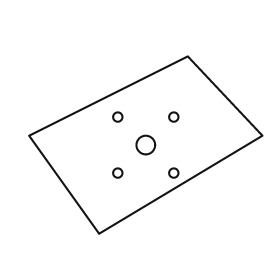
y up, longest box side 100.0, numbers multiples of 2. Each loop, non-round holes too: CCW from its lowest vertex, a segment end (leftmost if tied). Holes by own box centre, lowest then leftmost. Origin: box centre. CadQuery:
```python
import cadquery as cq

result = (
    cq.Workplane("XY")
    .moveTo(-20.0, -38.0)
    .lineTo(50.0, 4.0)
    .lineTo(18.0, 38.0)
    .lineTo(-50.0, 4.0)
    .close()
    .moveTo(-12.0, -12.0)
    .circle(2.0)
    .moveTo(12.0, -12.0)
    .circle(2.0)
    .moveTo(0.0, 0.0)
    .circle(4.0)
    .moveTo(-12.0, 12.0)
    .circle(2.0)
    .moveTo(12.0, 12.0)
    .circle(2.0)
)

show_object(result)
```